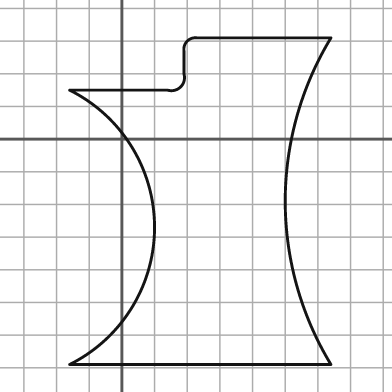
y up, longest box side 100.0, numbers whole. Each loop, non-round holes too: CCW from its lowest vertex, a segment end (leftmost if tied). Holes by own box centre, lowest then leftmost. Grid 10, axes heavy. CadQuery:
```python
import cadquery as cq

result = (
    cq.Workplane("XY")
    .moveTo(-16.0, -69.0)
    .lineTo(64.0, -69.0)
    .threePointArc((50.0, -19.0), (64.0, 31.0))
    .lineTo(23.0, 31.0)
    .threePointArc((20.0, 30.0), (19.0, 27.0))
    .lineTo(19.0, 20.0)
    .threePointArc((18.0, 16.0), (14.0, 15.0))
    .lineTo(-16.0, 15.0)
    .threePointArc((10.0, -27.0), (-16.0, -69.0))
    .close()
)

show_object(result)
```